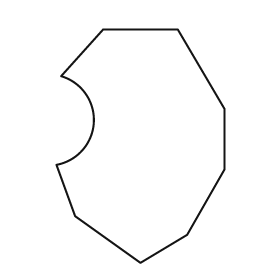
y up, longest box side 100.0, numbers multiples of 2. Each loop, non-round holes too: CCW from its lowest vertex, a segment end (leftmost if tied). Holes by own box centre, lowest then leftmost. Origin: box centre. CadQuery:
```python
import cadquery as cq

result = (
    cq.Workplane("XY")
    .moveTo(0.0, -50.0)
    .lineTo(20.0, -38.0)
    .lineTo(36.0, -10.0)
    .lineTo(36.0, 16.0)
    .lineTo(16.0, 50.0)
    .lineTo(-16.0, 50.0)
    .lineTo(-34.0, 30.0)
    .threePointArc((-20.0, 10.0), (-36.0, -8.0))
    .lineTo(-28.0, -30.0)
    .close()
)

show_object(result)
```